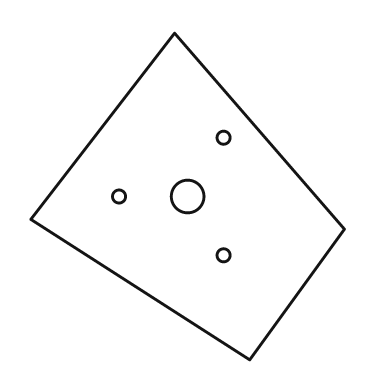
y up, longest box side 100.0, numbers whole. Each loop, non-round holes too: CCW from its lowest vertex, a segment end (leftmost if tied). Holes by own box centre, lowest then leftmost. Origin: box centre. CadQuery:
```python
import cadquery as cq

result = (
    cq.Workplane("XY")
    .moveTo(19.0, -50.0)
    .lineTo(48.0, -10.0)
    .lineTo(-4.0, 50.0)
    .lineTo(-48.0, -7.0)
    .close()
    .moveTo(11.0, -18.0)
    .circle(2.0)
    .moveTo(-21.0, 0.0)
    .circle(2.0)
    .moveTo(0.0, 0.0)
    .circle(5.0)
    .moveTo(11.0, 18.0)
    .circle(2.0)
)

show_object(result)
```